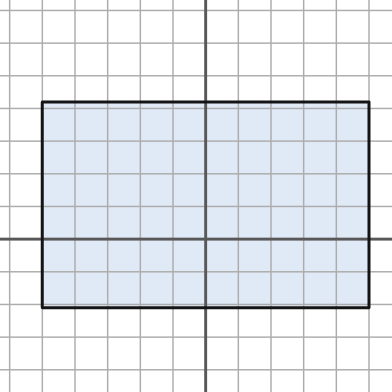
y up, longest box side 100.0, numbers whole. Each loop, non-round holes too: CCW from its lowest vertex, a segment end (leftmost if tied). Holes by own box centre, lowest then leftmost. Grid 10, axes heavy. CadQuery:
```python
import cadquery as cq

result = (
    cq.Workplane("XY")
    .moveTo(-50.0, -21.0)
    .lineTo(50.0, -21.0)
    .lineTo(50.0, 42.0)
    .lineTo(-50.0, 42.0)
    .close()
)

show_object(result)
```